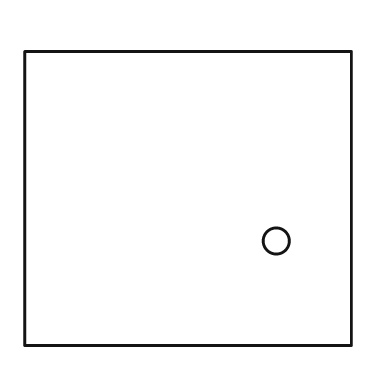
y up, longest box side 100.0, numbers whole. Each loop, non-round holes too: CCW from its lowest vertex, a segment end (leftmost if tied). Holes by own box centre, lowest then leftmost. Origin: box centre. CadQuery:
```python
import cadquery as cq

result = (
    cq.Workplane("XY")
    .moveTo(-50.0, -45.0)
    .lineTo(50.0, -45.0)
    .lineTo(50.0, 45.0)
    .lineTo(-50.0, 45.0)
    .close()
    .moveTo(27.0, -13.0)
    .circle(4.0)
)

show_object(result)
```